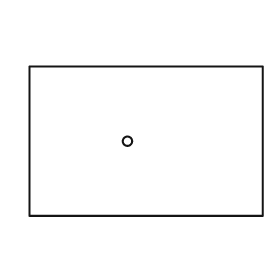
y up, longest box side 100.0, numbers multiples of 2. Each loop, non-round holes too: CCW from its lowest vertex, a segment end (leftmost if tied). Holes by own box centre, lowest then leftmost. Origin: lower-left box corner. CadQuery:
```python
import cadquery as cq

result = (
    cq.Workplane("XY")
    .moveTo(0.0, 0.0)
    .lineTo(100.0, 0.0)
    .lineTo(100.0, 64.0)
    .lineTo(0.0, 64.0)
    .close()
    .moveTo(42.0, 32.0)
    .circle(2.0)
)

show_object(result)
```